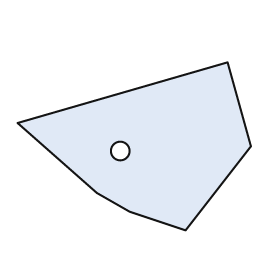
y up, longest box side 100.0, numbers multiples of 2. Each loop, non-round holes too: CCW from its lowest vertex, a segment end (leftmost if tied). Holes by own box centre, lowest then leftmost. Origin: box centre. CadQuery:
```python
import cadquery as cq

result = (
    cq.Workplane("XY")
    .moveTo(22.0, -36.0)
    .lineTo(50.0, 0.0)
    .lineTo(40.0, 36.0)
    .lineTo(-50.0, 10.0)
    .lineTo(-16.0, -20.0)
    .lineTo(-2.0, -28.0)
    .close()
    .moveTo(-6.0, -2.0)
    .circle(4.0)
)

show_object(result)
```